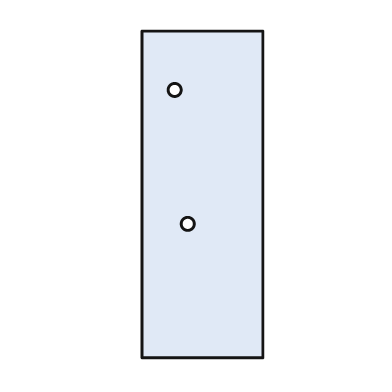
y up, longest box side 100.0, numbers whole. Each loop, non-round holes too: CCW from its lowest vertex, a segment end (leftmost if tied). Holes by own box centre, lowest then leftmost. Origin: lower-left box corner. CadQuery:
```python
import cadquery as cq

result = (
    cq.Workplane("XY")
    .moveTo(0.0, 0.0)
    .lineTo(37.0, 0.0)
    .lineTo(37.0, 100.0)
    .lineTo(0.0, 100.0)
    .close()
    .moveTo(14.0, 41.0)
    .circle(2.0)
    .moveTo(10.0, 82.0)
    .circle(2.0)
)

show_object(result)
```